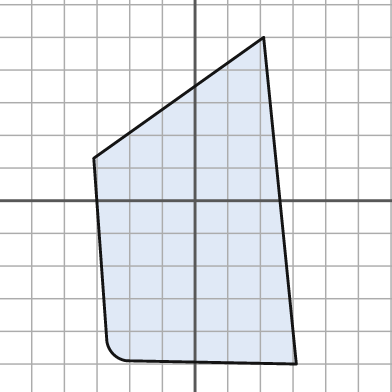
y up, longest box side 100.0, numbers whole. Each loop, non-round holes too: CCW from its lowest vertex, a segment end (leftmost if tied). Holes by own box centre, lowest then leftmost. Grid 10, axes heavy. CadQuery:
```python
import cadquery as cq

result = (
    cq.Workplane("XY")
    .moveTo(31.0, -50.0)
    .lineTo(21.0, 50.0)
    .lineTo(-31.0, 13.0)
    .lineTo(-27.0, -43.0)
    .threePointArc((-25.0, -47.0), (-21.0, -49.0))
    .close()
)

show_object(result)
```